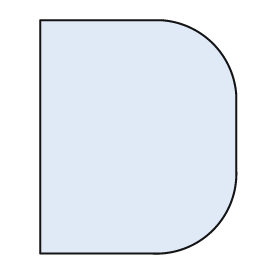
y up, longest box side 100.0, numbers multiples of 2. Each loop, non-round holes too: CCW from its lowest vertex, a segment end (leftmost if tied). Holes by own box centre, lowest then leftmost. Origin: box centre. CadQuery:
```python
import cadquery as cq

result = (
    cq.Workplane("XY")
    .moveTo(-42.0, -50.0)
    .lineTo(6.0, -50.0)
    .threePointArc((32.0, -40.0), (42.0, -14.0))
    .lineTo(42.0, 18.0)
    .threePointArc((32.0, 40.0), (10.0, 50.0))
    .lineTo(-42.0, 50.0)
    .close()
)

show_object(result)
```